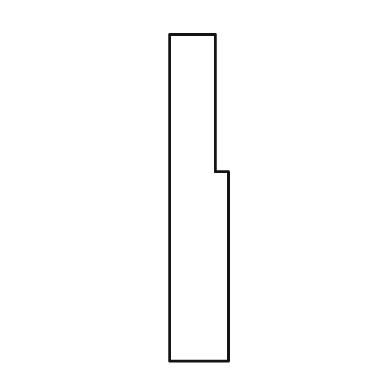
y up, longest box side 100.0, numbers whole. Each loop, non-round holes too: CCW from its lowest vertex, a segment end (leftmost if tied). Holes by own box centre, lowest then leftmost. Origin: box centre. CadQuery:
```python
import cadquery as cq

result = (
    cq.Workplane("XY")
    .moveTo(-9.0, -50.0)
    .lineTo(9.0, -50.0)
    .lineTo(9.0, 8.0)
    .lineTo(5.0, 8.0)
    .lineTo(5.0, 50.0)
    .lineTo(-9.0, 50.0)
    .close()
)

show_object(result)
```